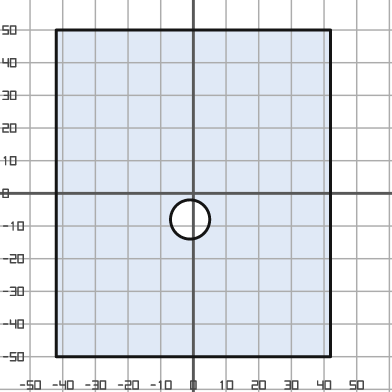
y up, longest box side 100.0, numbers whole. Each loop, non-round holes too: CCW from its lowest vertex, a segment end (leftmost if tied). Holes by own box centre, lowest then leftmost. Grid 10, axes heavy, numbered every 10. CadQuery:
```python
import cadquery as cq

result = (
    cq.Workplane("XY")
    .moveTo(-42.0, -50.0)
    .lineTo(42.0, -50.0)
    .lineTo(42.0, 50.0)
    .lineTo(-42.0, 50.0)
    .close()
    .moveTo(-1.0, -8.0)
    .circle(6.0)
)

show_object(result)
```